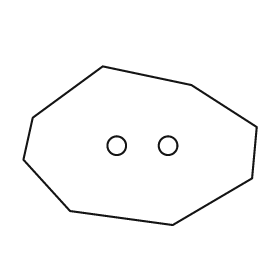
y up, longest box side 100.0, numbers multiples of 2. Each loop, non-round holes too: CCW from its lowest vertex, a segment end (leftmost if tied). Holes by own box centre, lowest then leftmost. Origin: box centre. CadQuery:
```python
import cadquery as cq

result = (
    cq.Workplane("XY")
    .moveTo(14.0, -34.0)
    .lineTo(48.0, -14.0)
    .lineTo(50.0, 8.0)
    .lineTo(22.0, 26.0)
    .lineTo(-16.0, 34.0)
    .lineTo(-46.0, 12.0)
    .lineTo(-50.0, -6.0)
    .lineTo(-30.0, -28.0)
    .close()
    .moveTo(-10.0, 0.0)
    .circle(4.0)
    .moveTo(12.0, 0.0)
    .circle(4.0)
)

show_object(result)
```